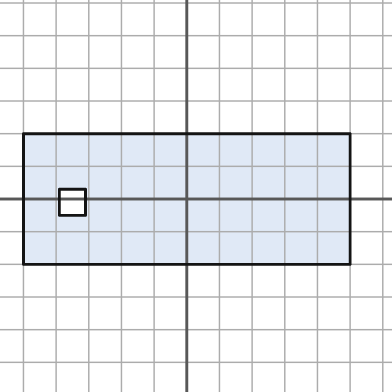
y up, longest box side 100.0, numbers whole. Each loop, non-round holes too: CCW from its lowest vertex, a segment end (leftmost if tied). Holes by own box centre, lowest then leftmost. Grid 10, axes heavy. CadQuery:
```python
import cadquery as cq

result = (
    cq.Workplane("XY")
    .moveTo(-50.0, -20.0)
    .lineTo(50.0, -20.0)
    .lineTo(50.0, 20.0)
    .lineTo(-50.0, 20.0)
    .close()
    .moveTo(-39.0, -5.0)
    .lineTo(-31.0, -5.0)
    .lineTo(-31.0, 3.0)
    .lineTo(-39.0, 3.0)
    .close()
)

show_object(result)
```